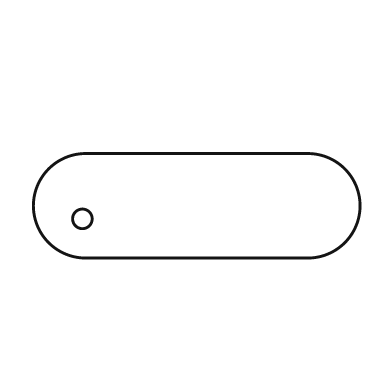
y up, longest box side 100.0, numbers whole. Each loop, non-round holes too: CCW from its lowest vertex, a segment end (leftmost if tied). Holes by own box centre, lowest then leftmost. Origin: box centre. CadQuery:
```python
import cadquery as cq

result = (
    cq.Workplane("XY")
    .moveTo(-34.0, -16.0)
    .lineTo(34.0, -16.0)
    .threePointArc((50.0, 0.0), (34.0, 16.0))
    .lineTo(-34.0, 16.0)
    .threePointArc((-50.0, 0.0), (-34.0, -16.0))
    .close()
    .moveTo(-35.0, -4.0)
    .circle(3.0)
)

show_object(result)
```